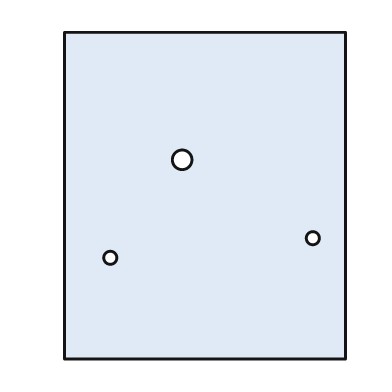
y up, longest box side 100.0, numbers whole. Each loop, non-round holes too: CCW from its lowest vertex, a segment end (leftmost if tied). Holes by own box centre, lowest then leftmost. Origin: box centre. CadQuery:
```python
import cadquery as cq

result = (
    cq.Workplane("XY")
    .moveTo(-43.0, -50.0)
    .lineTo(43.0, -50.0)
    .lineTo(43.0, 50.0)
    .lineTo(-43.0, 50.0)
    .close()
    .moveTo(-29.0, -19.0)
    .circle(2.0)
    .moveTo(33.0, -13.0)
    .circle(2.0)
    .moveTo(-7.0, 11.0)
    .circle(3.0)
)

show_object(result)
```